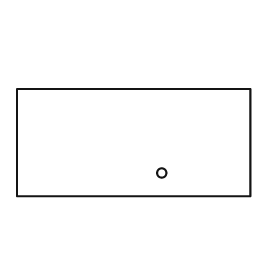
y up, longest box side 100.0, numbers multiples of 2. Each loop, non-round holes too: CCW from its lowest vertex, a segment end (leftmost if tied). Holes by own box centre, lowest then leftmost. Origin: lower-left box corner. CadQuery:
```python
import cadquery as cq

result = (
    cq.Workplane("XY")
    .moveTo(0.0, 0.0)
    .lineTo(100.0, 0.0)
    .lineTo(100.0, 46.0)
    .lineTo(0.0, 46.0)
    .close()
    .moveTo(62.0, 10.0)
    .circle(2.0)
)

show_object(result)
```